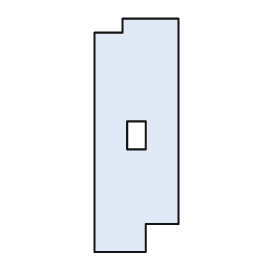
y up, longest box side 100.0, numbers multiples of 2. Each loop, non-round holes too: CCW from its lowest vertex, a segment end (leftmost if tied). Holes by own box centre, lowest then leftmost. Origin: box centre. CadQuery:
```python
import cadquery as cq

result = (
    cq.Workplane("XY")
    .moveTo(-18.0, -50.0)
    .lineTo(4.0, -50.0)
    .lineTo(4.0, -38.0)
    .lineTo(18.0, -38.0)
    .lineTo(18.0, 50.0)
    .lineTo(-6.0, 50.0)
    .lineTo(-6.0, 44.0)
    .lineTo(-18.0, 44.0)
    .close()
    .moveTo(-4.0, -6.0)
    .lineTo(4.0, -6.0)
    .lineTo(4.0, 6.0)
    .lineTo(-4.0, 6.0)
    .close()
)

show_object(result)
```